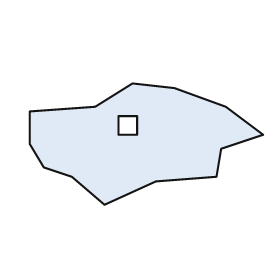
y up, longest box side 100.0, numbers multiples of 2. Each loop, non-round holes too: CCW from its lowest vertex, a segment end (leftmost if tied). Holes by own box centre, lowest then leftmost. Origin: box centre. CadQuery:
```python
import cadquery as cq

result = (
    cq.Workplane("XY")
    .moveTo(-18.0, -26.0)
    .lineTo(4.0, -16.0)
    .lineTo(30.0, -14.0)
    .lineTo(32.0, -2.0)
    .lineTo(50.0, 4.0)
    .lineTo(34.0, 16.0)
    .lineTo(12.0, 24.0)
    .lineTo(-6.0, 26.0)
    .lineTo(-22.0, 16.0)
    .lineTo(-50.0, 14.0)
    .lineTo(-50.0, 0.0)
    .lineTo(-44.0, -10.0)
    .lineTo(-32.0, -14.0)
    .close()
    .moveTo(-12.0, 4.0)
    .lineTo(-4.0, 4.0)
    .lineTo(-4.0, 12.0)
    .lineTo(-12.0, 12.0)
    .close()
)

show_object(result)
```